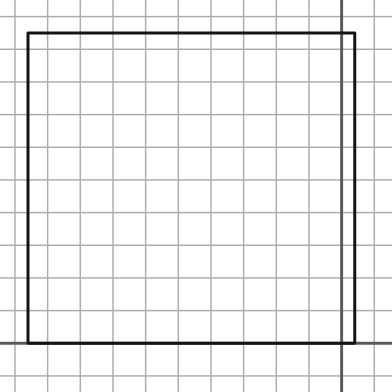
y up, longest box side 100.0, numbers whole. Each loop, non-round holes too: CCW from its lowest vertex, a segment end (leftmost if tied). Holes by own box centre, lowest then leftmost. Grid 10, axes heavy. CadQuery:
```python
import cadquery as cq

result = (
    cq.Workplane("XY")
    .moveTo(-96.0, 0.0)
    .lineTo(4.0, 0.0)
    .lineTo(4.0, 95.0)
    .lineTo(-96.0, 95.0)
    .close()
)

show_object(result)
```